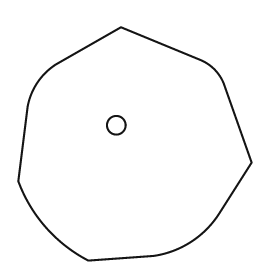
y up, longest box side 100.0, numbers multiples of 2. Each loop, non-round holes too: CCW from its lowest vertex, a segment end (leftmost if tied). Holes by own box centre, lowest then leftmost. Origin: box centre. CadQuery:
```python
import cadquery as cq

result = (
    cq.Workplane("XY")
    .moveTo(-20.0, -50.0)
    .lineTo(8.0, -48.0)
    .threePointArc((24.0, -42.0), (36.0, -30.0))
    .lineTo(50.0, -8.0)
    .lineTo(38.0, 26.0)
    .threePointArc((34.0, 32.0), (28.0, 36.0))
    .lineTo(-6.0, 50.0)
    .lineTo(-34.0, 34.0)
    .threePointArc((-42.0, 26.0), (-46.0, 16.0))
    .lineTo(-50.0, -16.0)
    .threePointArc((-38.0, -36.0), (-20.0, -50.0))
    .close()
    .moveTo(-8.0, 8.0)
    .circle(4.0)
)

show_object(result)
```